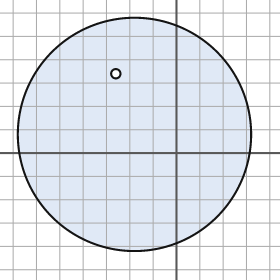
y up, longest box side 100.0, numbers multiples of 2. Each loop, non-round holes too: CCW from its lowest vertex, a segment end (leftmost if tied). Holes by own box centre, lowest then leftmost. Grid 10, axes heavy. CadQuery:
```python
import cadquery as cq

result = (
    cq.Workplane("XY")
    .moveTo(-18.0, 8.0)
    .circle(50.0)
    .moveTo(-26.0, 34.0)
    .circle(2.0)
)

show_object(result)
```